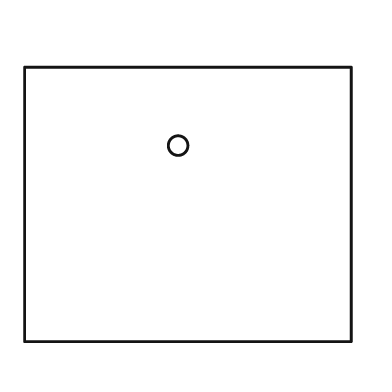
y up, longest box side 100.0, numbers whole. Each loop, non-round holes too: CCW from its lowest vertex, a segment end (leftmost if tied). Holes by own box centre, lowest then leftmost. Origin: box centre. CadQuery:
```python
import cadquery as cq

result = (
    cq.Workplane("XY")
    .moveTo(-50.0, -42.0)
    .lineTo(50.0, -42.0)
    .lineTo(50.0, 42.0)
    .lineTo(-50.0, 42.0)
    .close()
    .moveTo(-3.0, 18.0)
    .circle(3.0)
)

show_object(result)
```